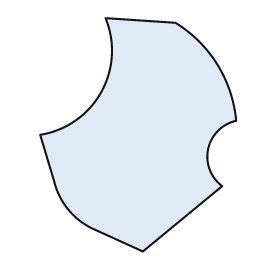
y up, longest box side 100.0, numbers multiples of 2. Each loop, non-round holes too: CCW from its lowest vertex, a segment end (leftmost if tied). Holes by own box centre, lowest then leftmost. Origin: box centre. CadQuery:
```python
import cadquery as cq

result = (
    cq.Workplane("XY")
    .moveTo(2.0, -50.0)
    .lineTo(36.0, -22.0)
    .threePointArc((30.0, -6.0), (42.0, 6.0))
    .threePointArc((34.0, 30.0), (16.0, 48.0))
    .lineTo(-14.0, 50.0)
    .threePointArc((-16.0, 18.0), (-42.0, 0.0))
    .lineTo(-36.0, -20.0)
    .threePointArc((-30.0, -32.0), (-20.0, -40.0))
    .close()
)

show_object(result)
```